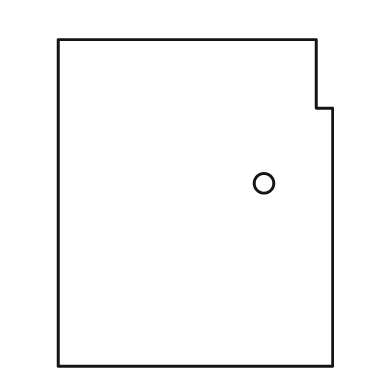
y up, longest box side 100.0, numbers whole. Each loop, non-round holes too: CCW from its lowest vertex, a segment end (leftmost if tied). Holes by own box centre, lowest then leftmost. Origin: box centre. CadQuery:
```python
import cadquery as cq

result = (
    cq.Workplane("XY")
    .moveTo(-42.0, -50.0)
    .lineTo(42.0, -50.0)
    .lineTo(42.0, 29.0)
    .lineTo(37.0, 29.0)
    .lineTo(37.0, 50.0)
    .lineTo(-42.0, 50.0)
    .close()
    .moveTo(21.0, 6.0)
    .circle(3.0)
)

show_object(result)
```